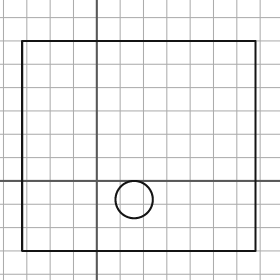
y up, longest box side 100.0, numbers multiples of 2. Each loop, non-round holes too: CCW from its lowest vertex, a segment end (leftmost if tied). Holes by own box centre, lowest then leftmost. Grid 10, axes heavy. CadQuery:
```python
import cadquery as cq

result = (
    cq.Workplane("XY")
    .moveTo(-32.0, -30.0)
    .lineTo(68.0, -30.0)
    .lineTo(68.0, 60.0)
    .lineTo(-32.0, 60.0)
    .close()
    .moveTo(16.0, -8.0)
    .circle(8.0)
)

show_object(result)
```